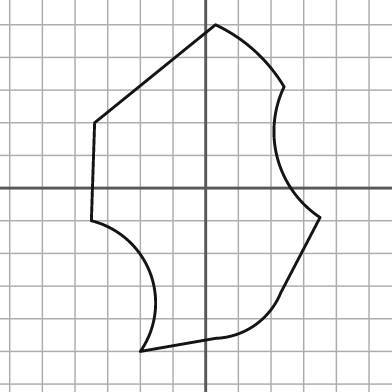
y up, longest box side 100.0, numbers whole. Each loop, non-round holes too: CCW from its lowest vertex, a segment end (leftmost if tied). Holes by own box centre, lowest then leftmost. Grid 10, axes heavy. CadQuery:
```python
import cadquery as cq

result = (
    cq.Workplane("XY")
    .moveTo(-20.0, -50.0)
    .lineTo(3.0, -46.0)
    .threePointArc((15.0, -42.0), (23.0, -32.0))
    .lineTo(35.0, -9.0)
    .threePointArc((22.0, 9.0), (24.0, 31.0))
    .threePointArc((15.0, 42.0), (3.0, 50.0))
    .lineTo(-34.0, 20.0)
    .lineTo(-35.0, -10.0)
    .threePointArc((-17.0, -26.0), (-20.0, -50.0))
    .close()
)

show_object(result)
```